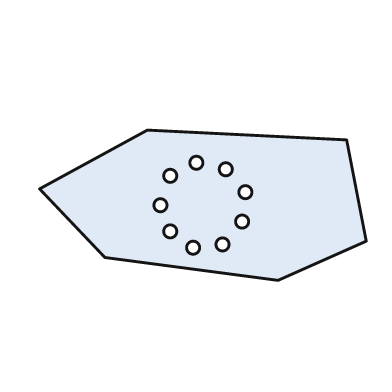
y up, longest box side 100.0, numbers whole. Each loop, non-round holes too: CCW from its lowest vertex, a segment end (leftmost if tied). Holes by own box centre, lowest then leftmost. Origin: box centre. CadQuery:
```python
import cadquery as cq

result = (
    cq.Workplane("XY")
    .moveTo(23.0, -23.0)
    .lineTo(50.0, -11.0)
    .lineTo(44.0, 20.0)
    .lineTo(-17.0, 23.0)
    .lineTo(-50.0, 5.0)
    .lineTo(-30.0, -16.0)
    .close()
    .moveTo(-3.0, -13.0)
    .circle(2.0)
    .moveTo(6.0, -12.0)
    .circle(2.0)
    .moveTo(-10.0, -8.0)
    .circle(2.0)
    .moveTo(12.0, -5.0)
    .circle(2.0)
    .moveTo(-13.0, 0.0)
    .circle(2.0)
    .moveTo(13.0, 4.0)
    .circle(2.0)
    .moveTo(-10.0, 9.0)
    .circle(2.0)
    .moveTo(7.0, 11.0)
    .circle(2.0)
    .moveTo(-2.0, 13.0)
    .circle(2.0)
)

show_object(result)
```